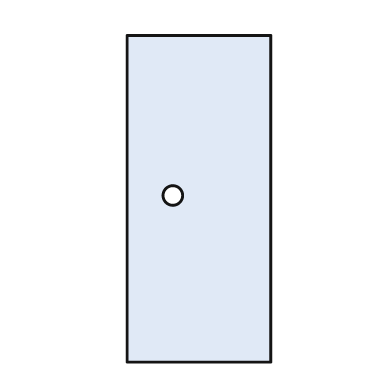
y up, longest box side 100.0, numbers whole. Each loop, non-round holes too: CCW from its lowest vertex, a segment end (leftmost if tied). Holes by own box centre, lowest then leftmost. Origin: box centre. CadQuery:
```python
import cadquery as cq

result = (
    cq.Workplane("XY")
    .moveTo(-22.0, -50.0)
    .lineTo(22.0, -50.0)
    .lineTo(22.0, 50.0)
    .lineTo(-22.0, 50.0)
    .close()
    .moveTo(-8.0, 1.0)
    .circle(3.0)
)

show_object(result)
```